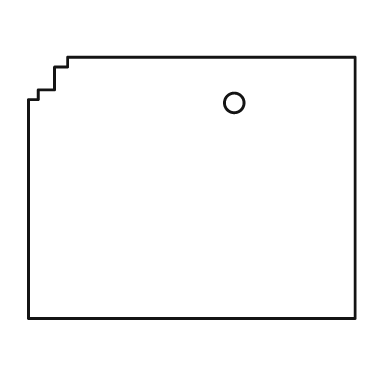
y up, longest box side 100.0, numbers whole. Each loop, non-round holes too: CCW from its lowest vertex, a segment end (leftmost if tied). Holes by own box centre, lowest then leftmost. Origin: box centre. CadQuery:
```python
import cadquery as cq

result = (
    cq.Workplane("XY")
    .moveTo(-50.0, -40.0)
    .lineTo(50.0, -40.0)
    .lineTo(50.0, 40.0)
    .lineTo(-38.0, 40.0)
    .lineTo(-38.0, 37.0)
    .lineTo(-42.0, 37.0)
    .lineTo(-42.0, 30.0)
    .lineTo(-47.0, 30.0)
    .lineTo(-47.0, 27.0)
    .lineTo(-50.0, 27.0)
    .close()
    .moveTo(13.0, 26.0)
    .circle(3.0)
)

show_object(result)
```